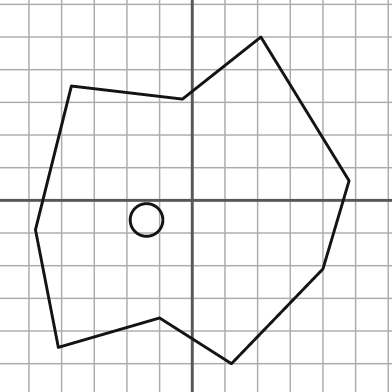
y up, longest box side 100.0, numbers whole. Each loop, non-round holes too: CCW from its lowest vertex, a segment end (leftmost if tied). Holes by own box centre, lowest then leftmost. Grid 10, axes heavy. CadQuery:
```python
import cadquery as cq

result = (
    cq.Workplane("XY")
    .moveTo(12.0, -50.0)
    .lineTo(40.0, -21.0)
    .lineTo(48.0, 6.0)
    .lineTo(21.0, 50.0)
    .lineTo(-3.0, 31.0)
    .lineTo(-37.0, 35.0)
    .lineTo(-48.0, -9.0)
    .lineTo(-41.0, -45.0)
    .lineTo(-10.0, -36.0)
    .close()
    .moveTo(-14.0, -6.0)
    .circle(5.0)
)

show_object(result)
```